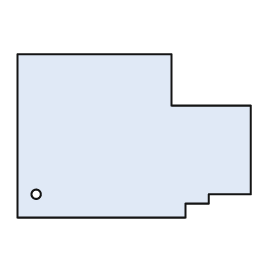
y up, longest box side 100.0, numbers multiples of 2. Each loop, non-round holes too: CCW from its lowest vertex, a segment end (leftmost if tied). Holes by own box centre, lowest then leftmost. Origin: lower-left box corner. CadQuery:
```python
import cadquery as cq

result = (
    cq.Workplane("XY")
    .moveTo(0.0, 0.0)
    .lineTo(72.0, 0.0)
    .lineTo(72.0, 6.0)
    .lineTo(82.0, 6.0)
    .lineTo(82.0, 10.0)
    .lineTo(100.0, 10.0)
    .lineTo(100.0, 48.0)
    .lineTo(66.0, 48.0)
    .lineTo(66.0, 70.0)
    .lineTo(0.0, 70.0)
    .close()
    .moveTo(8.0, 10.0)
    .circle(2.0)
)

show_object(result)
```